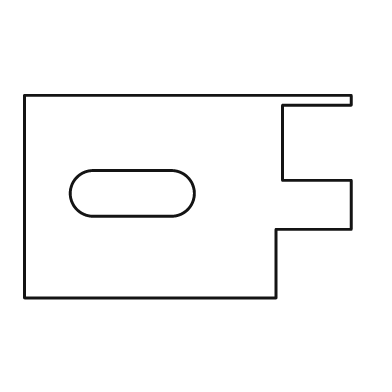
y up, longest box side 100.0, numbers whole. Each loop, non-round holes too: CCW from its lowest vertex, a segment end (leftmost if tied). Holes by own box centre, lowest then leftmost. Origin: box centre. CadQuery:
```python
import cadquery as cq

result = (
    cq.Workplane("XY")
    .moveTo(-50.0, -31.0)
    .lineTo(27.0, -31.0)
    .lineTo(27.0, -10.0)
    .lineTo(50.0, -10.0)
    .lineTo(50.0, 5.0)
    .lineTo(29.0, 5.0)
    .lineTo(29.0, 28.0)
    .lineTo(50.0, 28.0)
    .lineTo(50.0, 31.0)
    .lineTo(-50.0, 31.0)
    .close()
    .moveTo(-29.0, -6.0)
    .lineTo(-5.0, -6.0)
    .threePointArc((2.0, 1.0), (-5.0, 8.0))
    .lineTo(-29.0, 8.0)
    .threePointArc((-36.0, 1.0), (-29.0, -6.0))
    .close()
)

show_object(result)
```